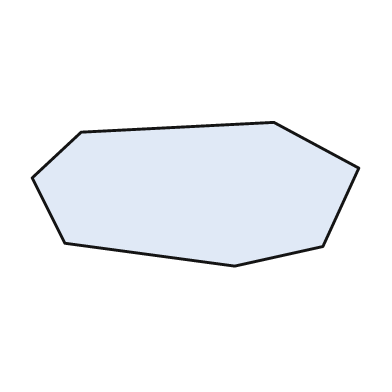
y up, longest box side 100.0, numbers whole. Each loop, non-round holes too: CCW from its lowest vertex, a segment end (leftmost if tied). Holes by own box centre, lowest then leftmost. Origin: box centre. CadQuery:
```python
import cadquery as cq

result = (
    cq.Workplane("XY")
    .moveTo(12.0, -22.0)
    .lineTo(39.0, -16.0)
    .lineTo(50.0, 8.0)
    .lineTo(24.0, 22.0)
    .lineTo(-35.0, 19.0)
    .lineTo(-50.0, 5.0)
    .lineTo(-40.0, -15.0)
    .close()
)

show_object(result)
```